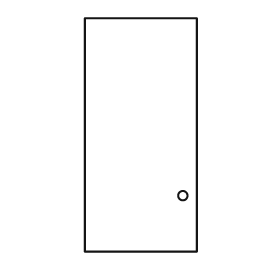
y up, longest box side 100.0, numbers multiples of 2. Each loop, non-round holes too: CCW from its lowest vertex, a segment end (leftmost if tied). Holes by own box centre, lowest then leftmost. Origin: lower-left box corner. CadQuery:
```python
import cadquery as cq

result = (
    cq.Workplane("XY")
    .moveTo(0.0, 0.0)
    .lineTo(48.0, 0.0)
    .lineTo(48.0, 100.0)
    .lineTo(0.0, 100.0)
    .close()
    .moveTo(42.0, 24.0)
    .circle(2.0)
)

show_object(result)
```